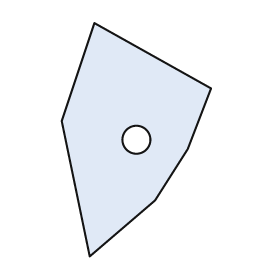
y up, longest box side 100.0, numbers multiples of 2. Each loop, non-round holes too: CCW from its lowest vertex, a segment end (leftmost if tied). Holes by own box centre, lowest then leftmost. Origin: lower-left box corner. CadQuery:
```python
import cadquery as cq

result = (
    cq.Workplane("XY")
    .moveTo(12.0, 0.0)
    .lineTo(40.0, 24.0)
    .lineTo(54.0, 46.0)
    .lineTo(64.0, 72.0)
    .lineTo(14.0, 100.0)
    .lineTo(0.0, 58.0)
    .close()
    .moveTo(32.0, 50.0)
    .circle(6.0)
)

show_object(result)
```